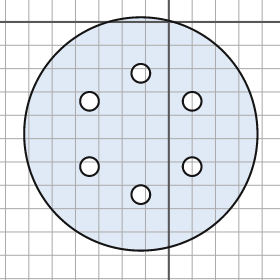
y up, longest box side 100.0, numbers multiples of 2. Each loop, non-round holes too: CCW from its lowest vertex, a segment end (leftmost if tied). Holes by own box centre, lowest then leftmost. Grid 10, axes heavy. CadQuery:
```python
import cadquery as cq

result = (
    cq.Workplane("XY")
    .moveTo(-12.0, -48.0)
    .circle(50.0)
    .moveTo(-12.0, -74.0)
    .circle(4.0)
    .moveTo(-34.0, -62.0)
    .circle(4.0)
    .moveTo(10.0, -62.0)
    .circle(4.0)
    .moveTo(-34.0, -34.0)
    .circle(4.0)
    .moveTo(10.0, -34.0)
    .circle(4.0)
    .moveTo(-12.0, -22.0)
    .circle(4.0)
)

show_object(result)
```